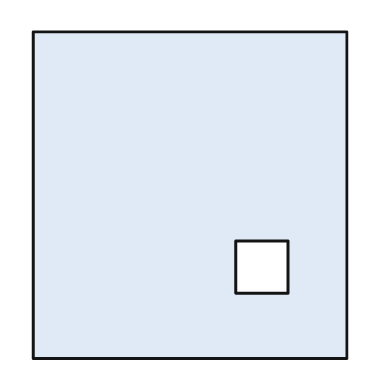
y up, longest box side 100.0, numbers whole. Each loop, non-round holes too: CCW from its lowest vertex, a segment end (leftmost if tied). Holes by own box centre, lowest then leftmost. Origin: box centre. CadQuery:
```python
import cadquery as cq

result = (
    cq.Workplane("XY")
    .moveTo(-48.0, -50.0)
    .lineTo(48.0, -50.0)
    .lineTo(48.0, 50.0)
    .lineTo(-48.0, 50.0)
    .close()
    .moveTo(14.0, -30.0)
    .lineTo(30.0, -30.0)
    .lineTo(30.0, -14.0)
    .lineTo(14.0, -14.0)
    .close()
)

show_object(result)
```